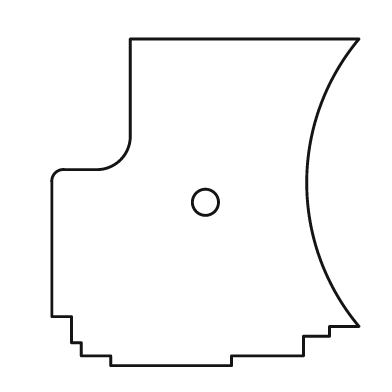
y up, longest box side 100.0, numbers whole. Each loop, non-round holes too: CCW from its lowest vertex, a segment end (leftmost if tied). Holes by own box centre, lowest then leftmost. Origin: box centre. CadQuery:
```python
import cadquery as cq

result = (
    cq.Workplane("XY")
    .moveTo(-29.0, -50.0)
    .lineTo(8.0, -50.0)
    .lineTo(8.0, -47.0)
    .lineTo(30.0, -47.0)
    .lineTo(30.0, -41.0)
    .lineTo(38.0, -41.0)
    .lineTo(38.0, -38.0)
    .lineTo(47.0, -38.0)
    .threePointArc((31.0, 6.0), (47.0, 50.0))
    .lineTo(-23.0, 50.0)
    .lineTo(-23.0, 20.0)
    .threePointArc((-26.0, 13.0), (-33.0, 10.0))
    .lineTo(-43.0, 10.0)
    .threePointArc((-46.0, 9.0), (-47.0, 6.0))
    .lineTo(-47.0, -35.0)
    .lineTo(-41.0, -35.0)
    .lineTo(-41.0, -43.0)
    .lineTo(-38.0, -43.0)
    .lineTo(-38.0, -47.0)
    .lineTo(-29.0, -47.0)
    .close()
    .moveTo(0.0, 0.0)
    .circle(4.0)
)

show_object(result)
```